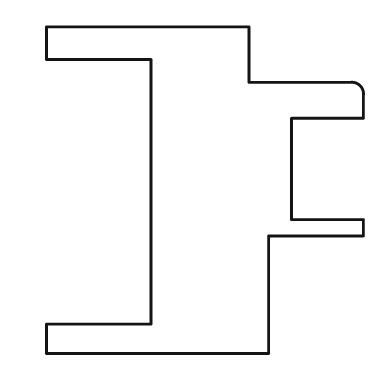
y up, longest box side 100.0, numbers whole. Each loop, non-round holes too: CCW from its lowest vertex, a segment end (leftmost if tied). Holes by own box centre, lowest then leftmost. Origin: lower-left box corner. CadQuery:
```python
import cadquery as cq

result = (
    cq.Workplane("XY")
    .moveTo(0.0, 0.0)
    .lineTo(68.0, 0.0)
    .lineTo(68.0, 36.0)
    .lineTo(97.0, 36.0)
    .lineTo(97.0, 41.0)
    .lineTo(75.0, 41.0)
    .lineTo(75.0, 72.0)
    .lineTo(97.0, 72.0)
    .lineTo(97.0, 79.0)
    .threePointArc((96.0, 82.0), (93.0, 83.0))
    .lineTo(62.0, 83.0)
    .lineTo(62.0, 100.0)
    .lineTo(0.0, 100.0)
    .lineTo(0.0, 90.0)
    .lineTo(32.0, 90.0)
    .lineTo(32.0, 9.0)
    .lineTo(0.0, 9.0)
    .close()
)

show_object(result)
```